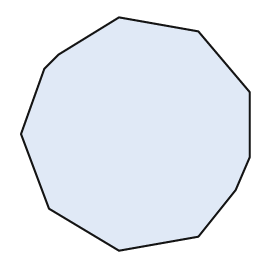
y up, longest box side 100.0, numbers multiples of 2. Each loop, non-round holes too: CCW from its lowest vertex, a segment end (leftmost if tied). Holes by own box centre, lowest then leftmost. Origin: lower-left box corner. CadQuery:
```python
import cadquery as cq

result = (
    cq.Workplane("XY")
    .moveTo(42.0, 0.0)
    .lineTo(76.0, 6.0)
    .lineTo(92.0, 26.0)
    .lineTo(98.0, 40.0)
    .lineTo(98.0, 68.0)
    .lineTo(76.0, 94.0)
    .lineTo(42.0, 100.0)
    .lineTo(16.0, 84.0)
    .lineTo(10.0, 78.0)
    .lineTo(0.0, 50.0)
    .lineTo(12.0, 18.0)
    .close()
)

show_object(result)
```